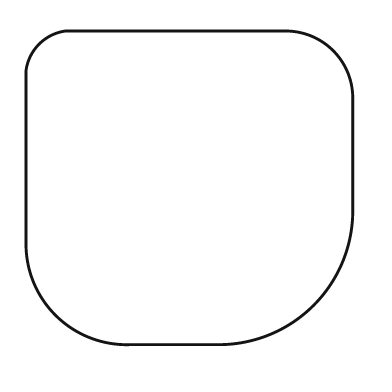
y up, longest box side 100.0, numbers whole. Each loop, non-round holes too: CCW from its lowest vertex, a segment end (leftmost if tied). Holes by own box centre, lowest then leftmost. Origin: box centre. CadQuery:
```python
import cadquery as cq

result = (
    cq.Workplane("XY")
    .moveTo(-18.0, -48.0)
    .lineTo(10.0, -48.0)
    .threePointArc((38.0, -36.0), (50.0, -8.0))
    .lineTo(50.0, 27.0)
    .threePointArc((44.0, 42.0), (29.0, 48.0))
    .lineTo(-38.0, 48.0)
    .threePointArc((-46.0, 44.0), (-50.0, 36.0))
    .lineTo(-50.0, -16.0)
    .threePointArc((-41.0, -39.0), (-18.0, -48.0))
    .close()
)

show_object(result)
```